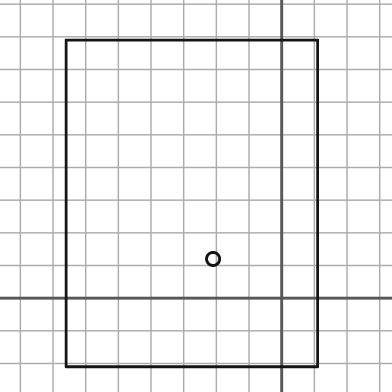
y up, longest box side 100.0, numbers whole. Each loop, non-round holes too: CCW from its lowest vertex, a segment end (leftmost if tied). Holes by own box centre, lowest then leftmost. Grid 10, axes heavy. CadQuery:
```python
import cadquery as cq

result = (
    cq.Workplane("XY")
    .moveTo(-66.0, -21.0)
    .lineTo(11.0, -21.0)
    .lineTo(11.0, 79.0)
    .lineTo(-66.0, 79.0)
    .close()
    .moveTo(-21.0, 12.0)
    .circle(2.0)
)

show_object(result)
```